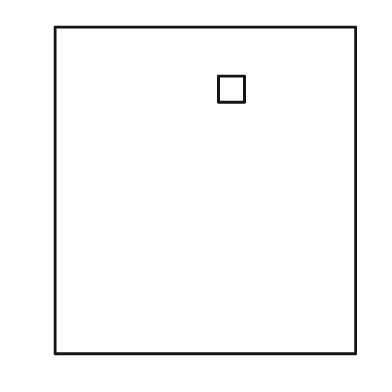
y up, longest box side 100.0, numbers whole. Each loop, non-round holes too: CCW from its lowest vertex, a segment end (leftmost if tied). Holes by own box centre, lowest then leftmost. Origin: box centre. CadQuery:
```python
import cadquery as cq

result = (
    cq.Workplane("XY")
    .moveTo(-46.0, -50.0)
    .lineTo(46.0, -50.0)
    .lineTo(46.0, 50.0)
    .lineTo(-46.0, 50.0)
    .close()
    .moveTo(4.0, 27.0)
    .lineTo(12.0, 27.0)
    .lineTo(12.0, 35.0)
    .lineTo(4.0, 35.0)
    .close()
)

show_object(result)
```